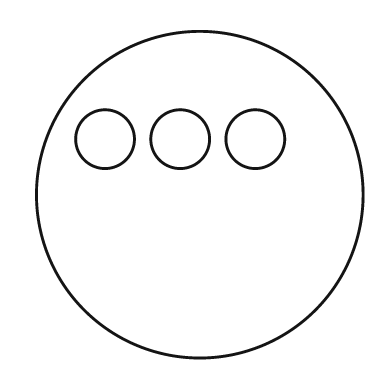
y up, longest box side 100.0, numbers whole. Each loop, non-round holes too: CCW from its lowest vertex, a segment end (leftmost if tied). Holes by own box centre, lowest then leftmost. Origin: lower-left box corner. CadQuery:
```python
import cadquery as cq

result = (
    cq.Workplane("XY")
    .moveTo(50.0, 50.0)
    .circle(50.0)
    .moveTo(21.0, 67.0)
    .circle(9.0)
    .moveTo(44.0, 67.0)
    .circle(9.0)
    .moveTo(67.0, 67.0)
    .circle(9.0)
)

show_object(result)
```